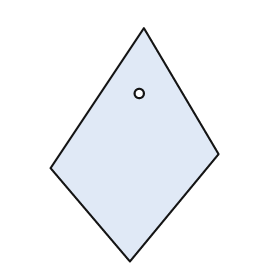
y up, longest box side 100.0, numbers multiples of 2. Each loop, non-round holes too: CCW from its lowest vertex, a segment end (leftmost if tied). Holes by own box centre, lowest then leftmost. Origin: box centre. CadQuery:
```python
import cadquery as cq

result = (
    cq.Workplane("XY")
    .moveTo(-2.0, -50.0)
    .lineTo(36.0, -4.0)
    .lineTo(4.0, 50.0)
    .lineTo(-36.0, -10.0)
    .close()
    .moveTo(2.0, 22.0)
    .circle(2.0)
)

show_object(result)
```